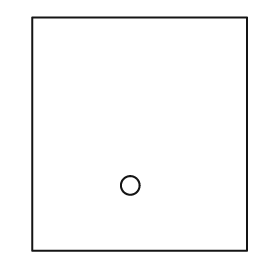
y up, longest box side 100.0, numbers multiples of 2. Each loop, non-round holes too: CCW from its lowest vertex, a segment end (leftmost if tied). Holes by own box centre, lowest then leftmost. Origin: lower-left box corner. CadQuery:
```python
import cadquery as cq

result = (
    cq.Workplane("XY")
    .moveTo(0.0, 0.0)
    .lineTo(92.0, 0.0)
    .lineTo(92.0, 100.0)
    .lineTo(0.0, 100.0)
    .close()
    .moveTo(42.0, 28.0)
    .circle(4.0)
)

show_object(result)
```